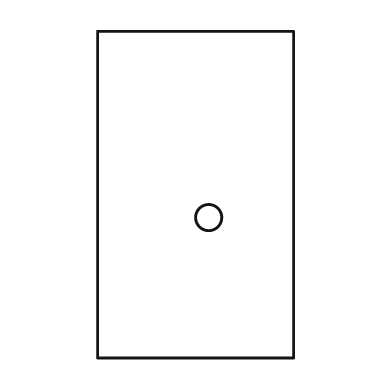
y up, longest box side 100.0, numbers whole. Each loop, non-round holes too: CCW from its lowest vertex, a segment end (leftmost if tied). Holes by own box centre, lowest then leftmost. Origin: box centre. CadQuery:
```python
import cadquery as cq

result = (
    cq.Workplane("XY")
    .moveTo(-30.0, -50.0)
    .lineTo(30.0, -50.0)
    .lineTo(30.0, 50.0)
    .lineTo(-30.0, 50.0)
    .close()
    .moveTo(4.0, -7.0)
    .circle(4.0)
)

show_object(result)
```